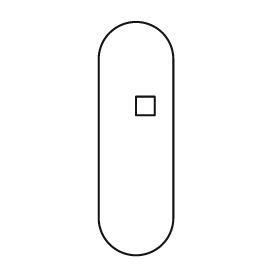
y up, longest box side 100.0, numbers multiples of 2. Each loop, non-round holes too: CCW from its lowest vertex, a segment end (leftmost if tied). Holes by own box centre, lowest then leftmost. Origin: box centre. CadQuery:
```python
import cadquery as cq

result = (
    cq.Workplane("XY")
    .moveTo(-16.0, -34.0)
    .threePointArc((0.0, -50.0), (16.0, -34.0))
    .lineTo(16.0, 34.0)
    .threePointArc((0.0, 50.0), (-16.0, 34.0))
    .close()
    .moveTo(0.0, 10.0)
    .lineTo(8.0, 10.0)
    .lineTo(8.0, 18.0)
    .lineTo(0.0, 18.0)
    .close()
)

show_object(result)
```